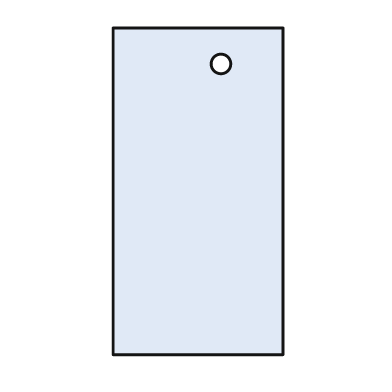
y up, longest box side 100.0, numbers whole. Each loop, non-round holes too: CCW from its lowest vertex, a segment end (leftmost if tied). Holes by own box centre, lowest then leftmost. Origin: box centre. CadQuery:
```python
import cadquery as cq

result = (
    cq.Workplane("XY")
    .moveTo(-26.0, -50.0)
    .lineTo(26.0, -50.0)
    .lineTo(26.0, 50.0)
    .lineTo(-26.0, 50.0)
    .close()
    .moveTo(7.0, 39.0)
    .circle(3.0)
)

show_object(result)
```